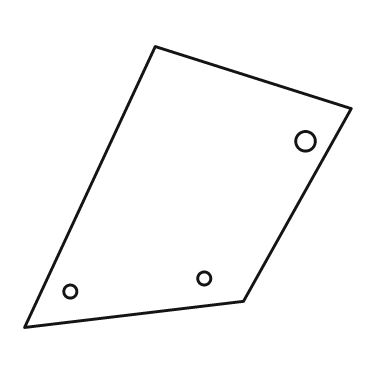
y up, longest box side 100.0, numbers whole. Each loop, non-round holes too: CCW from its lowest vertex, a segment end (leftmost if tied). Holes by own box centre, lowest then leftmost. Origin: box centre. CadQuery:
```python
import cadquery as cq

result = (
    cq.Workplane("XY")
    .moveTo(-50.0, -43.0)
    .lineTo(17.0, -35.0)
    .lineTo(50.0, 24.0)
    .lineTo(-10.0, 43.0)
    .close()
    .moveTo(-36.0, -32.0)
    .circle(2.0)
    .moveTo(5.0, -28.0)
    .circle(2.0)
    .moveTo(36.0, 14.0)
    .circle(3.0)
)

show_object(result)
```